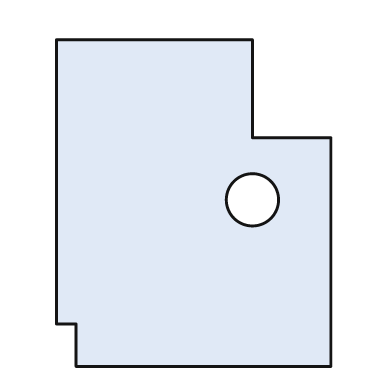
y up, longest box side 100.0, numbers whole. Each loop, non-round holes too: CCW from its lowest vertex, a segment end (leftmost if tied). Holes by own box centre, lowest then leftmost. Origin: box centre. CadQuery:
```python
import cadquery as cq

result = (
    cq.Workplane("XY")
    .moveTo(-36.0, -50.0)
    .lineTo(42.0, -50.0)
    .lineTo(42.0, 20.0)
    .lineTo(18.0, 20.0)
    .lineTo(18.0, 50.0)
    .lineTo(-42.0, 50.0)
    .lineTo(-42.0, -37.0)
    .lineTo(-36.0, -37.0)
    .close()
    .moveTo(18.0, 1.0)
    .circle(8.0)
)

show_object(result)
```